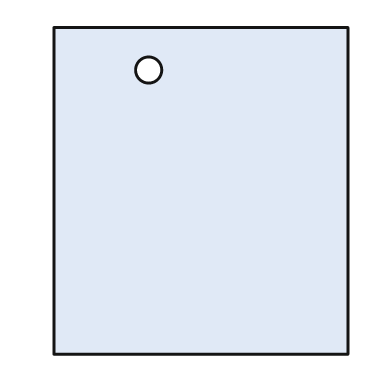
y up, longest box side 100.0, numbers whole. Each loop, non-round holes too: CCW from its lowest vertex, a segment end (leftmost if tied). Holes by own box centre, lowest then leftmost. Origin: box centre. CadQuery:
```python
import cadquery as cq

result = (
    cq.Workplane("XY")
    .moveTo(-45.0, -50.0)
    .lineTo(45.0, -50.0)
    .lineTo(45.0, 50.0)
    .lineTo(-45.0, 50.0)
    .close()
    .moveTo(-16.0, 37.0)
    .circle(4.0)
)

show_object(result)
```